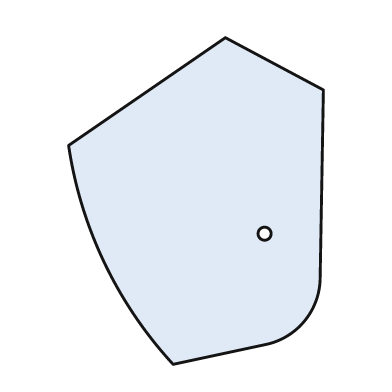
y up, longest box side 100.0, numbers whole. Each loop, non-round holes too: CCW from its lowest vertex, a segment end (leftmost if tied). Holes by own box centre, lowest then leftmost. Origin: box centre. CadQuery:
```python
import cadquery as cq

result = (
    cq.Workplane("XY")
    .moveTo(-7.0, -50.0)
    .lineTo(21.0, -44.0)
    .threePointArc((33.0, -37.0), (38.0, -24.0))
    .lineTo(39.0, 34.0)
    .lineTo(9.0, 50.0)
    .lineTo(-39.0, 17.0)
    .threePointArc((-28.0, -19.0), (-7.0, -50.0))
    .close()
    .moveTo(21.0, -10.0)
    .circle(2.0)
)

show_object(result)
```